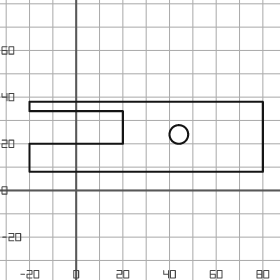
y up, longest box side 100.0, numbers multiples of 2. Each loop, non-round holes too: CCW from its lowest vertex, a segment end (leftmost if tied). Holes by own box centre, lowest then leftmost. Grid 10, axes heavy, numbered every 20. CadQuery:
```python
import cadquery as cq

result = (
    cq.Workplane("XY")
    .moveTo(-20.0, 8.0)
    .lineTo(80.0, 8.0)
    .lineTo(80.0, 38.0)
    .lineTo(-20.0, 38.0)
    .lineTo(-20.0, 34.0)
    .lineTo(20.0, 34.0)
    .lineTo(20.0, 20.0)
    .lineTo(-20.0, 20.0)
    .close()
    .moveTo(44.0, 24.0)
    .circle(4.0)
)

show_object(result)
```